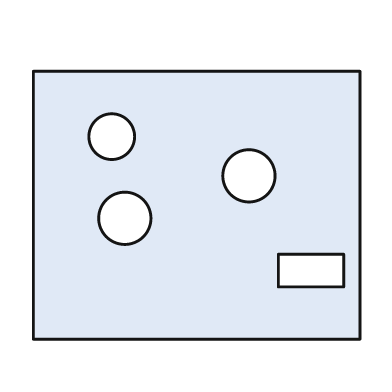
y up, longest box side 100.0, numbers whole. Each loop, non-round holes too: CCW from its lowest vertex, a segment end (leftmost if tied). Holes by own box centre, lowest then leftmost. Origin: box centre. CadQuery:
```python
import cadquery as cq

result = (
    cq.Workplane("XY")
    .moveTo(-50.0, -41.0)
    .lineTo(50.0, -41.0)
    .lineTo(50.0, 41.0)
    .lineTo(-50.0, 41.0)
    .close()
    .moveTo(25.0, -25.0)
    .lineTo(45.0, -25.0)
    .lineTo(45.0, -15.0)
    .lineTo(25.0, -15.0)
    .close()
    .moveTo(-22.0, -4.0)
    .circle(8.0)
    .moveTo(16.0, 9.0)
    .circle(8.0)
    .moveTo(-26.0, 21.0)
    .circle(7.0)
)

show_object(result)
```